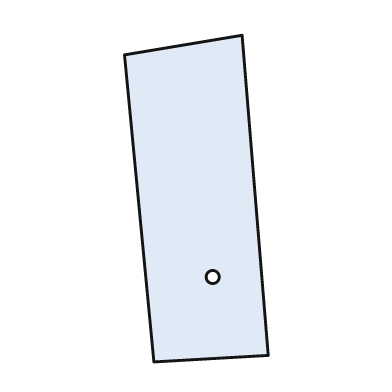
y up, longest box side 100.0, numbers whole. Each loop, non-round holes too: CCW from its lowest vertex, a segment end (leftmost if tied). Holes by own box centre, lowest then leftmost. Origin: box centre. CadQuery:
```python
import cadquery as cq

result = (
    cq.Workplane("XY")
    .moveTo(-13.0, -50.0)
    .lineTo(22.0, -48.0)
    .lineTo(14.0, 50.0)
    .lineTo(-22.0, 44.0)
    .close()
    .moveTo(5.0, -24.0)
    .circle(2.0)
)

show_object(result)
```